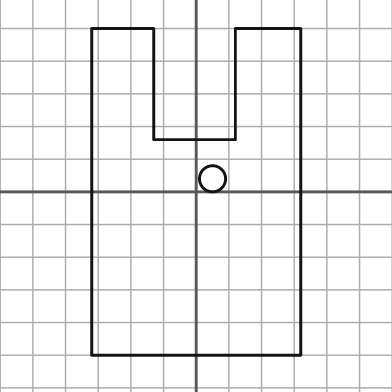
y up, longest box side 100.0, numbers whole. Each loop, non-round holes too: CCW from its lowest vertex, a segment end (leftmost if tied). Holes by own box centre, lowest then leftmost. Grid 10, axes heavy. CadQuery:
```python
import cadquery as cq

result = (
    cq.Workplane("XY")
    .moveTo(-32.0, -50.0)
    .lineTo(32.0, -50.0)
    .lineTo(32.0, 50.0)
    .lineTo(12.0, 50.0)
    .lineTo(12.0, 16.0)
    .lineTo(-13.0, 16.0)
    .lineTo(-13.0, 50.0)
    .lineTo(-32.0, 50.0)
    .close()
    .moveTo(5.0, 4.0)
    .circle(4.0)
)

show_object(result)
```